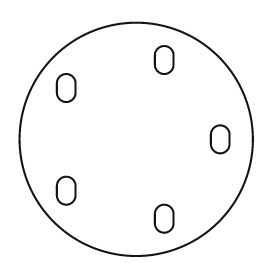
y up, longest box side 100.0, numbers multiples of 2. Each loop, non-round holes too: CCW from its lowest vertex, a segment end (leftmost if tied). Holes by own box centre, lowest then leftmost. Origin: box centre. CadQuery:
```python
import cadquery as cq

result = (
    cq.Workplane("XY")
    .moveTo(0.0, 0.0)
    .circle(50.0)
    .moveTo(8.0, -36.0)
    .threePointArc((12.0, -40.0), (16.0, -36.0))
    .lineTo(16.0, -32.0)
    .threePointArc((12.0, -28.0), (8.0, -32.0))
    .close()
    .moveTo(-34.0, -24.0)
    .threePointArc((-30.0, -28.0), (-26.0, -24.0))
    .lineTo(-26.0, -20.0)
    .threePointArc((-30.0, -16.0), (-34.0, -20.0))
    .close()
    .moveTo(32.0, -2.0)
    .threePointArc((36.0, -6.0), (40.0, -2.0))
    .lineTo(40.0, 2.0)
    .threePointArc((36.0, 6.0), (32.0, 2.0))
    .close()
    .moveTo(-34.0, 20.0)
    .threePointArc((-30.0, 16.0), (-26.0, 20.0))
    .lineTo(-26.0, 24.0)
    .threePointArc((-30.0, 28.0), (-34.0, 24.0))
    .close()
    .moveTo(8.0, 32.0)
    .threePointArc((12.0, 28.0), (16.0, 32.0))
    .lineTo(16.0, 36.0)
    .threePointArc((12.0, 40.0), (8.0, 36.0))
    .close()
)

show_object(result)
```